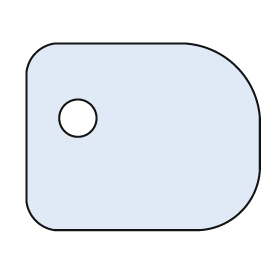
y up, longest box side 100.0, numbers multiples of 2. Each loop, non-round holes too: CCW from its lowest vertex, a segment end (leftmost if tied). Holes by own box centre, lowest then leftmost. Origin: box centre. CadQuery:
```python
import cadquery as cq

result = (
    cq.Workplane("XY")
    .moveTo(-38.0, -40.0)
    .lineTo(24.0, -40.0)
    .threePointArc((42.0, -32.0), (50.0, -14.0))
    .lineTo(50.0, 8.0)
    .threePointArc((40.0, 30.0), (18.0, 40.0))
    .lineTo(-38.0, 40.0)
    .threePointArc((-46.0, 36.0), (-50.0, 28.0))
    .lineTo(-50.0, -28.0)
    .threePointArc((-46.0, -36.0), (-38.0, -40.0))
    .close()
    .moveTo(-28.0, 8.0)
    .circle(8.0)
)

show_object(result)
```